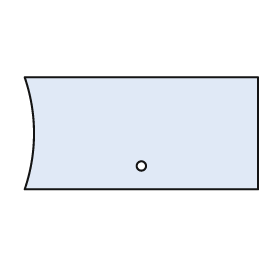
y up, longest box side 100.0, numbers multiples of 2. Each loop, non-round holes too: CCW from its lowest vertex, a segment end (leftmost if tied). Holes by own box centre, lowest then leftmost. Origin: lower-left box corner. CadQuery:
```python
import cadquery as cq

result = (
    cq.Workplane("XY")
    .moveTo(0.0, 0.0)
    .lineTo(100.0, 0.0)
    .lineTo(100.0, 48.0)
    .lineTo(0.0, 48.0)
    .threePointArc((4.0, 24.0), (0.0, 0.0))
    .close()
    .moveTo(50.0, 10.0)
    .circle(2.0)
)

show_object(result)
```